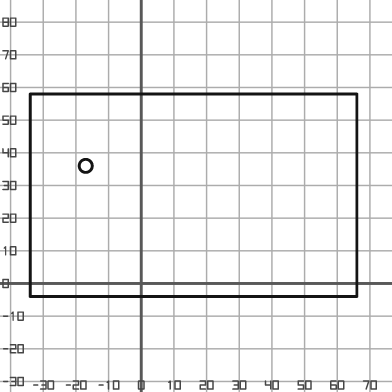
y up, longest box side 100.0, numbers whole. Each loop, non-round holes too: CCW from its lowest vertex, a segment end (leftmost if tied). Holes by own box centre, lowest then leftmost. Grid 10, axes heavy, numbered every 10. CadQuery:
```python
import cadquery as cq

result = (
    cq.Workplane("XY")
    .moveTo(-34.0, -4.0)
    .lineTo(66.0, -4.0)
    .lineTo(66.0, 58.0)
    .lineTo(-34.0, 58.0)
    .close()
    .moveTo(-17.0, 36.0)
    .circle(2.0)
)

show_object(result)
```